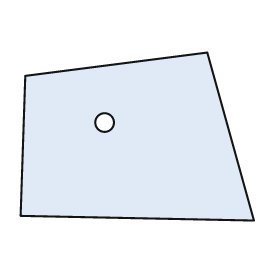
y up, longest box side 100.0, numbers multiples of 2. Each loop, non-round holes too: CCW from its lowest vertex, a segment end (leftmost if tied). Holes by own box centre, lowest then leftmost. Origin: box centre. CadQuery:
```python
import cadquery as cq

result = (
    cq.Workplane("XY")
    .moveTo(50.0, -36.0)
    .lineTo(30.0, 36.0)
    .lineTo(-48.0, 26.0)
    .lineTo(-50.0, -34.0)
    .close()
    .moveTo(-14.0, 6.0)
    .circle(4.0)
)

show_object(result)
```